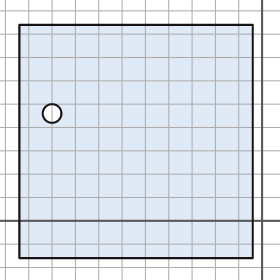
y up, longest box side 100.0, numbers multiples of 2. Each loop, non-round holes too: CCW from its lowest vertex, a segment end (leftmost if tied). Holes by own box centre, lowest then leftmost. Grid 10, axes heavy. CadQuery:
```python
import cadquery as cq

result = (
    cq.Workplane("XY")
    .moveTo(-104.0, -16.0)
    .lineTo(-4.0, -16.0)
    .lineTo(-4.0, 84.0)
    .lineTo(-104.0, 84.0)
    .close()
    .moveTo(-90.0, 46.0)
    .circle(4.0)
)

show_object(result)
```